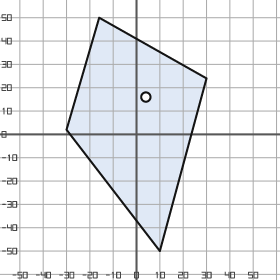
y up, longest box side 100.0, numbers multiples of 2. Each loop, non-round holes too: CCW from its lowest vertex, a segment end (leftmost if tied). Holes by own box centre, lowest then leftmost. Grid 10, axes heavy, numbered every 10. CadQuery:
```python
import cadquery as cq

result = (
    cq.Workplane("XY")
    .moveTo(10.0, -50.0)
    .lineTo(30.0, 24.0)
    .lineTo(-16.0, 50.0)
    .lineTo(-30.0, 2.0)
    .close()
    .moveTo(4.0, 16.0)
    .circle(2.0)
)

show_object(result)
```